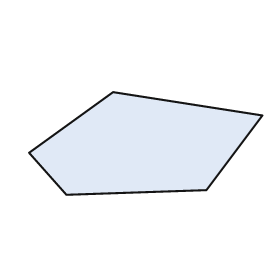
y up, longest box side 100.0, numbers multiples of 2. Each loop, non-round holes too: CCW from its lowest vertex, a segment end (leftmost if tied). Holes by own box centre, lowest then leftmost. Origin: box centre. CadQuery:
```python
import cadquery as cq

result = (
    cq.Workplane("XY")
    .moveTo(-34.0, -22.0)
    .lineTo(26.0, -20.0)
    .lineTo(50.0, 12.0)
    .lineTo(-14.0, 22.0)
    .lineTo(-50.0, -4.0)
    .close()
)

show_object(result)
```